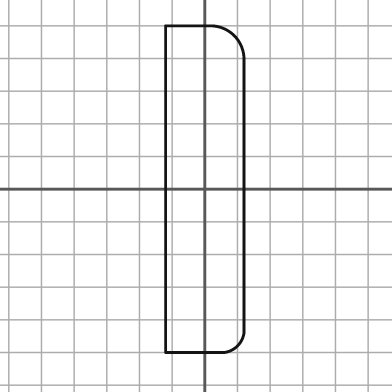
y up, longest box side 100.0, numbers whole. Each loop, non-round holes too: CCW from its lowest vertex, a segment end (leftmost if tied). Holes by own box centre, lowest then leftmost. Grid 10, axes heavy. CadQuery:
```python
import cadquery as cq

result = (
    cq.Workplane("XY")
    .moveTo(-12.0, -50.0)
    .lineTo(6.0, -50.0)
    .threePointArc((10.0, -48.0), (12.0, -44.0))
    .lineTo(12.0, 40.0)
    .threePointArc((9.0, 47.0), (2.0, 50.0))
    .lineTo(-12.0, 50.0)
    .close()
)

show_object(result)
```